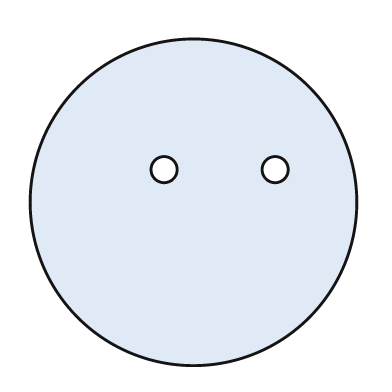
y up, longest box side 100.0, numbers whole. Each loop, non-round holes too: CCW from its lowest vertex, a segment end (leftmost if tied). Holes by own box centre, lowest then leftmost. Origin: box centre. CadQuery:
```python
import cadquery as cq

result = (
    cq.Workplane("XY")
    .moveTo(0.0, 0.0)
    .circle(50.0)
    .moveTo(-9.0, 10.0)
    .circle(4.0)
    .moveTo(25.0, 10.0)
    .circle(4.0)
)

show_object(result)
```